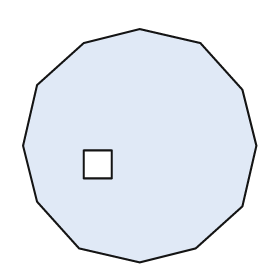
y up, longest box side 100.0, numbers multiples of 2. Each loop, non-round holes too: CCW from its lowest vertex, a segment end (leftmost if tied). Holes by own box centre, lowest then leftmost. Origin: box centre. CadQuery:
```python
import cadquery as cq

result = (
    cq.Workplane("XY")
    .moveTo(0.0, -50.0)
    .lineTo(24.0, -44.0)
    .lineTo(44.0, -26.0)
    .lineTo(50.0, 0.0)
    .lineTo(44.0, 24.0)
    .lineTo(26.0, 44.0)
    .lineTo(0.0, 50.0)
    .lineTo(-24.0, 44.0)
    .lineTo(-44.0, 26.0)
    .lineTo(-50.0, 0.0)
    .lineTo(-44.0, -24.0)
    .lineTo(-26.0, -44.0)
    .close()
    .moveTo(-24.0, -14.0)
    .lineTo(-12.0, -14.0)
    .lineTo(-12.0, -2.0)
    .lineTo(-24.0, -2.0)
    .close()
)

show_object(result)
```